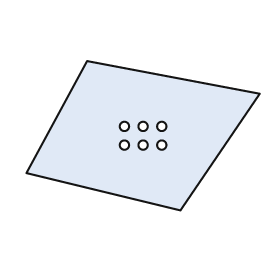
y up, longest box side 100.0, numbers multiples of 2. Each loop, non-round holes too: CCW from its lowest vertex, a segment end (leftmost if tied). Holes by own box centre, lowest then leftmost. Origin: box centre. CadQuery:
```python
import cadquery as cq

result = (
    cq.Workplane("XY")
    .moveTo(16.0, -32.0)
    .lineTo(50.0, 18.0)
    .lineTo(-24.0, 32.0)
    .lineTo(-50.0, -16.0)
    .close()
    .moveTo(-8.0, -4.0)
    .circle(2.0)
    .moveTo(0.0, -4.0)
    .circle(2.0)
    .moveTo(8.0, -4.0)
    .circle(2.0)
    .moveTo(-8.0, 4.0)
    .circle(2.0)
    .moveTo(0.0, 4.0)
    .circle(2.0)
    .moveTo(8.0, 4.0)
    .circle(2.0)
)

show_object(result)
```